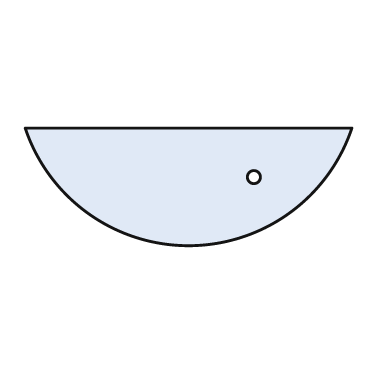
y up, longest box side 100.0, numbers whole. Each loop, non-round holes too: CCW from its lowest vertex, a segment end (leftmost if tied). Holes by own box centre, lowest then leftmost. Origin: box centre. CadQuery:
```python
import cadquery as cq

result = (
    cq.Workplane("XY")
    .moveTo(-50.0, 18.0)
    .threePointArc((0.0, -18.0), (50.0, 18.0))
    .close()
    .moveTo(20.0, 3.0)
    .circle(2.0)
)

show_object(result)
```